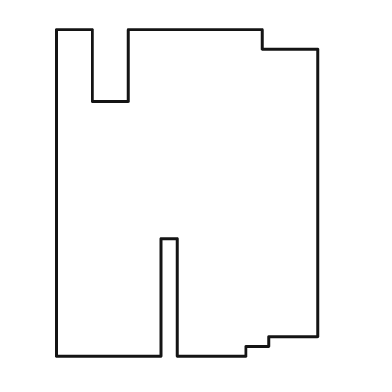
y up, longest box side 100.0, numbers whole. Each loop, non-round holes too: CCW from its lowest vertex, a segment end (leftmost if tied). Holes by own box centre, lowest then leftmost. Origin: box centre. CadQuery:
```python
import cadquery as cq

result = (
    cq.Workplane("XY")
    .moveTo(-40.0, -50.0)
    .lineTo(-8.0, -50.0)
    .lineTo(-8.0, -14.0)
    .lineTo(-3.0, -14.0)
    .lineTo(-3.0, -50.0)
    .lineTo(18.0, -50.0)
    .lineTo(18.0, -47.0)
    .lineTo(25.0, -47.0)
    .lineTo(25.0, -44.0)
    .lineTo(40.0, -44.0)
    .lineTo(40.0, 44.0)
    .lineTo(23.0, 44.0)
    .lineTo(23.0, 50.0)
    .lineTo(-18.0, 50.0)
    .lineTo(-18.0, 28.0)
    .lineTo(-29.0, 28.0)
    .lineTo(-29.0, 50.0)
    .lineTo(-40.0, 50.0)
    .close()
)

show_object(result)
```